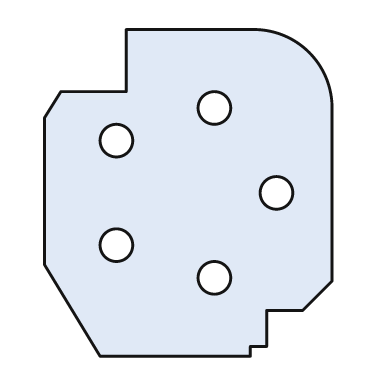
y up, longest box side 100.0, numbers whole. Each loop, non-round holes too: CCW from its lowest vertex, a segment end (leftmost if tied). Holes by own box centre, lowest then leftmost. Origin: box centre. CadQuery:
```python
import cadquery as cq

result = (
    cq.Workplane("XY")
    .moveTo(-27.0, -50.0)
    .lineTo(19.0, -50.0)
    .lineTo(19.0, -47.0)
    .lineTo(24.0, -47.0)
    .lineTo(24.0, -36.0)
    .lineTo(35.0, -36.0)
    .lineTo(44.0, -27.0)
    .lineTo(44.0, 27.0)
    .threePointArc((37.0, 43.0), (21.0, 50.0))
    .lineTo(-19.0, 50.0)
    .lineTo(-19.0, 31.0)
    .lineTo(-39.0, 31.0)
    .lineTo(-44.0, 23.0)
    .lineTo(-44.0, -22.0)
    .close()
    .moveTo(8.0, -26.0)
    .circle(5.0)
    .moveTo(-22.0, -16.0)
    .circle(5.0)
    .moveTo(27.0, 0.0)
    .circle(5.0)
    .moveTo(-22.0, 16.0)
    .circle(5.0)
    .moveTo(8.0, 26.0)
    .circle(5.0)
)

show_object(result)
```